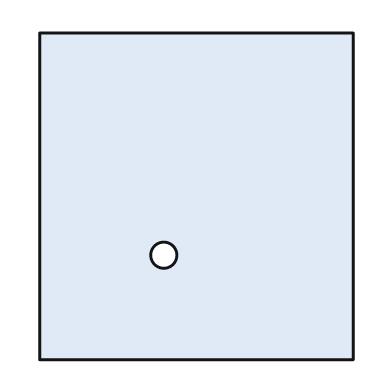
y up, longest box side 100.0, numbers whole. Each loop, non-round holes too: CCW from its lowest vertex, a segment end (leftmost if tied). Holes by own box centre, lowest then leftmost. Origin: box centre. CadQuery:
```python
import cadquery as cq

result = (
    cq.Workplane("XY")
    .moveTo(-48.0, -50.0)
    .lineTo(48.0, -50.0)
    .lineTo(48.0, 50.0)
    .lineTo(-48.0, 50.0)
    .close()
    .moveTo(-10.0, -18.0)
    .circle(4.0)
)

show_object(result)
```